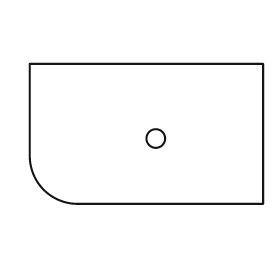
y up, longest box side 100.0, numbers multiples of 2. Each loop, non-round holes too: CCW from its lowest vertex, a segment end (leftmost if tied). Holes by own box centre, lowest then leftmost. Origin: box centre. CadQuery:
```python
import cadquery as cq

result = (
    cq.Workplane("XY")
    .moveTo(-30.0, -30.0)
    .lineTo(50.0, -30.0)
    .lineTo(50.0, 30.0)
    .lineTo(-50.0, 30.0)
    .lineTo(-50.0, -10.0)
    .threePointArc((-44.0, -24.0), (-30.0, -30.0))
    .close()
    .moveTo(4.0, -2.0)
    .circle(4.0)
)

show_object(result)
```